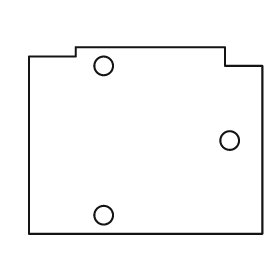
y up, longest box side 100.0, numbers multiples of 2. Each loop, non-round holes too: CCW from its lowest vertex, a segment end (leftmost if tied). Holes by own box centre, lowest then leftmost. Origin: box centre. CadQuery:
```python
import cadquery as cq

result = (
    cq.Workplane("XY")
    .moveTo(-50.0, -40.0)
    .lineTo(50.0, -40.0)
    .lineTo(50.0, 32.0)
    .lineTo(34.0, 32.0)
    .lineTo(34.0, 40.0)
    .lineTo(-30.0, 40.0)
    .lineTo(-30.0, 36.0)
    .lineTo(-50.0, 36.0)
    .close()
    .moveTo(-18.0, -32.0)
    .circle(4.0)
    .moveTo(36.0, 0.0)
    .circle(4.0)
    .moveTo(-18.0, 32.0)
    .circle(4.0)
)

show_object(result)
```